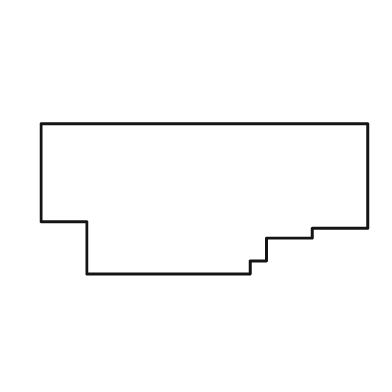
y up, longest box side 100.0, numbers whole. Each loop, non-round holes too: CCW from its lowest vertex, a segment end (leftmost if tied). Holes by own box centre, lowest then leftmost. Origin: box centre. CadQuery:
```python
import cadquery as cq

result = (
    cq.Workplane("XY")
    .moveTo(-36.0, -23.0)
    .lineTo(14.0, -23.0)
    .lineTo(14.0, -19.0)
    .lineTo(19.0, -19.0)
    .lineTo(19.0, -12.0)
    .lineTo(33.0, -12.0)
    .lineTo(33.0, -9.0)
    .lineTo(50.0, -9.0)
    .lineTo(50.0, 23.0)
    .lineTo(-50.0, 23.0)
    .lineTo(-50.0, -7.0)
    .lineTo(-36.0, -7.0)
    .close()
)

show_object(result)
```